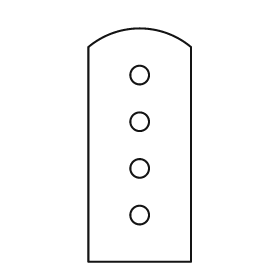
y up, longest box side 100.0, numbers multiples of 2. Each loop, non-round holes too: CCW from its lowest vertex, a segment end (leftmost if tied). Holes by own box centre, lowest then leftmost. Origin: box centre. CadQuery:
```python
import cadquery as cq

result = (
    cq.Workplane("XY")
    .moveTo(-22.0, -50.0)
    .lineTo(22.0, -50.0)
    .lineTo(22.0, 42.0)
    .threePointArc((0.0, 50.0), (-22.0, 42.0))
    .close()
    .moveTo(0.0, -30.0)
    .circle(4.0)
    .moveTo(0.0, -10.0)
    .circle(4.0)
    .moveTo(0.0, 10.0)
    .circle(4.0)
    .moveTo(0.0, 30.0)
    .circle(4.0)
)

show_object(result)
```